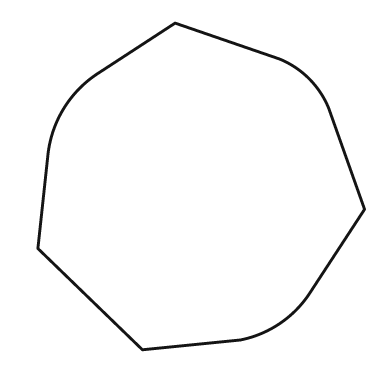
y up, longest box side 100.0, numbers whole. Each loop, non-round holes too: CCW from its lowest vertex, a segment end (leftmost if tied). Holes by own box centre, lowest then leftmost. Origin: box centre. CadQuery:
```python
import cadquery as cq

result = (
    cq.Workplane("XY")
    .moveTo(-18.0, -50.0)
    .lineTo(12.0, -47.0)
    .threePointArc((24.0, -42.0), (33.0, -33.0))
    .lineTo(50.0, -7.0)
    .lineTo(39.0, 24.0)
    .threePointArc((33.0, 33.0), (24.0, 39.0))
    .lineTo(-8.0, 50.0)
    .lineTo(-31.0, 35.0)
    .threePointArc((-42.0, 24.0), (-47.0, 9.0))
    .lineTo(-50.0, -19.0)
    .close()
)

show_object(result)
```